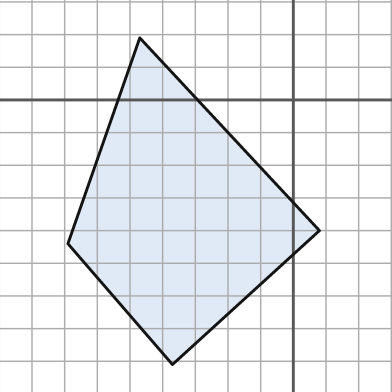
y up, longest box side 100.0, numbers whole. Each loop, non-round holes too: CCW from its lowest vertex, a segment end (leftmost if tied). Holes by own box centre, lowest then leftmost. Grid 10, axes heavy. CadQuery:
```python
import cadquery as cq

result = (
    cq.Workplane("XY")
    .moveTo(-37.0, -81.0)
    .lineTo(8.0, -40.0)
    .lineTo(-47.0, 19.0)
    .lineTo(-69.0, -44.0)
    .close()
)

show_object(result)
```